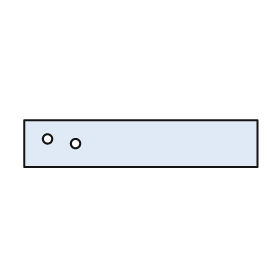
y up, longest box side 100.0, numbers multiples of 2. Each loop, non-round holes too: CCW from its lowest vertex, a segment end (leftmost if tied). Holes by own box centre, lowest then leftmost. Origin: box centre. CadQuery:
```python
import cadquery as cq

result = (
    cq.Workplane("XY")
    .moveTo(-50.0, -10.0)
    .lineTo(50.0, -10.0)
    .lineTo(50.0, 10.0)
    .lineTo(-50.0, 10.0)
    .close()
    .moveTo(-28.0, 0.0)
    .circle(2.0)
    .moveTo(-40.0, 2.0)
    .circle(2.0)
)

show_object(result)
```